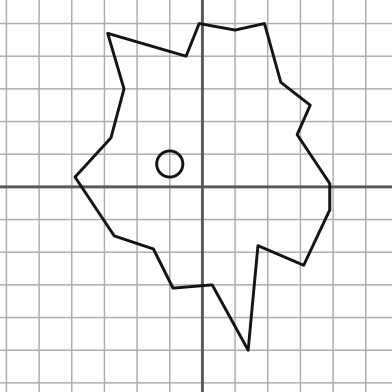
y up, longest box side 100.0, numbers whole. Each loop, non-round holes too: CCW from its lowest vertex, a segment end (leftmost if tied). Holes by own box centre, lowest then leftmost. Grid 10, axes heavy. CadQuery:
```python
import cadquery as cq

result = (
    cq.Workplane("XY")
    .moveTo(14.0, -50.0)
    .lineTo(17.0, -18.0)
    .lineTo(31.0, -24.0)
    .lineTo(39.0, -7.0)
    .lineTo(39.0, 1.0)
    .lineTo(29.0, 16.0)
    .lineTo(33.0, 25.0)
    .lineTo(24.0, 32.0)
    .lineTo(19.0, 50.0)
    .lineTo(10.0, 48.0)
    .lineTo(-1.0, 50.0)
    .lineTo(-5.0, 40.0)
    .lineTo(-29.0, 47.0)
    .lineTo(-24.0, 30.0)
    .lineTo(-28.0, 15.0)
    .lineTo(-39.0, 3.0)
    .lineTo(-27.0, -15.0)
    .lineTo(-15.0, -19.0)
    .lineTo(-9.0, -31.0)
    .lineTo(3.0, -30.0)
    .close()
    .moveTo(-10.0, 7.0)
    .circle(4.0)
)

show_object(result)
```